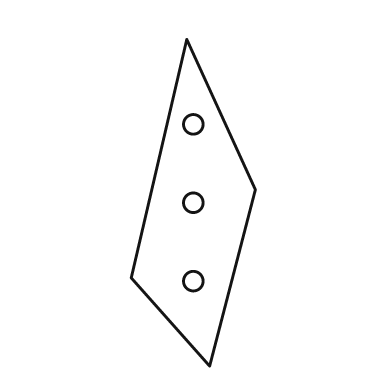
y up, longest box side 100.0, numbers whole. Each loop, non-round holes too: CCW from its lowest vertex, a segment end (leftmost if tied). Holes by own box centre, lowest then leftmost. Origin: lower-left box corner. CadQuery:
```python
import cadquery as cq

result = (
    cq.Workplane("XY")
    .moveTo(24.0, 0.0)
    .lineTo(38.0, 54.0)
    .lineTo(17.0, 100.0)
    .lineTo(0.0, 27.0)
    .close()
    .moveTo(19.0, 26.0)
    .circle(3.0)
    .moveTo(19.0, 50.0)
    .circle(3.0)
    .moveTo(19.0, 74.0)
    .circle(3.0)
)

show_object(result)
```